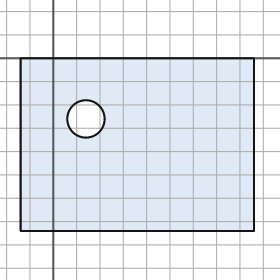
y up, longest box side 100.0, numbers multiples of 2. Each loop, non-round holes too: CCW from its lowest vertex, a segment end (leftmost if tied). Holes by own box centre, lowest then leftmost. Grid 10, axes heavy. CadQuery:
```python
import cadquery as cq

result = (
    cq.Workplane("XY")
    .moveTo(-14.0, -74.0)
    .lineTo(86.0, -74.0)
    .lineTo(86.0, 0.0)
    .lineTo(-14.0, 0.0)
    .close()
    .moveTo(14.0, -26.0)
    .circle(8.0)
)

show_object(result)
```